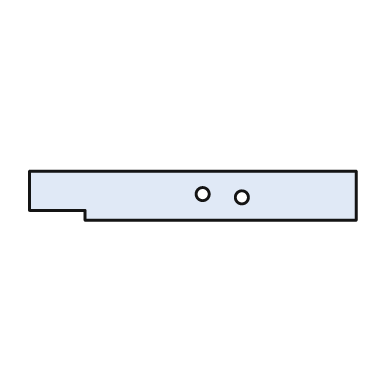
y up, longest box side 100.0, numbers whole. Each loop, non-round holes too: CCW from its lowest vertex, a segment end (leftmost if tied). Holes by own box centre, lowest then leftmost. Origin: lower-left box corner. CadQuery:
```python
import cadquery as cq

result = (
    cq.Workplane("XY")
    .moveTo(17.0, 0.0)
    .lineTo(100.0, 0.0)
    .lineTo(100.0, 15.0)
    .lineTo(0.0, 15.0)
    .lineTo(0.0, 3.0)
    .lineTo(17.0, 3.0)
    .close()
    .moveTo(65.0, 7.0)
    .circle(2.0)
    .moveTo(53.0, 8.0)
    .circle(2.0)
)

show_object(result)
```